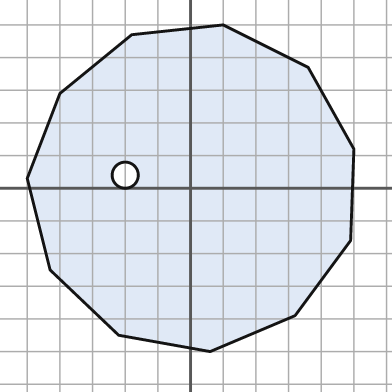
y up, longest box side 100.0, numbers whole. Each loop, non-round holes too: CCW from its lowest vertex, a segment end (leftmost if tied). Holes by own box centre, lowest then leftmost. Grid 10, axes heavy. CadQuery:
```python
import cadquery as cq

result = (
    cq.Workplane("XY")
    .moveTo(6.0, -50.0)
    .lineTo(32.0, -39.0)
    .lineTo(49.0, -16.0)
    .lineTo(50.0, 12.0)
    .lineTo(36.0, 37.0)
    .lineTo(10.0, 50.0)
    .lineTo(-18.0, 47.0)
    .lineTo(-40.0, 29.0)
    .lineTo(-50.0, 3.0)
    .lineTo(-43.0, -25.0)
    .lineTo(-22.0, -45.0)
    .close()
    .moveTo(-20.0, 4.0)
    .circle(4.0)
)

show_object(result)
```